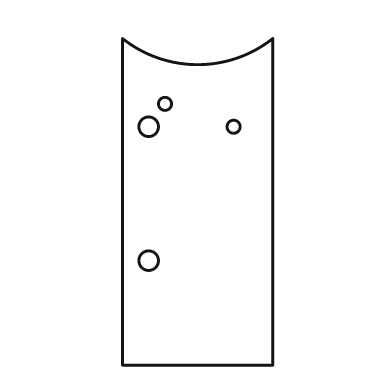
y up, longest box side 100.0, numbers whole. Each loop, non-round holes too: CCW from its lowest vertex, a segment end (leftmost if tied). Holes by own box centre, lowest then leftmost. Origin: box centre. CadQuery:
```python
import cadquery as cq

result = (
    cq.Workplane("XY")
    .moveTo(-23.0, -50.0)
    .lineTo(23.0, -50.0)
    .lineTo(23.0, 50.0)
    .threePointArc((0.0, 42.0), (-23.0, 50.0))
    .close()
    .moveTo(-15.0, -18.0)
    .circle(3.0)
    .moveTo(-15.0, 23.0)
    .circle(3.0)
    .moveTo(11.0, 23.0)
    .circle(2.0)
    .moveTo(-10.0, 30.0)
    .circle(2.0)
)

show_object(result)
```